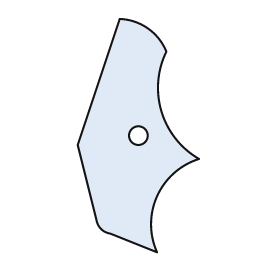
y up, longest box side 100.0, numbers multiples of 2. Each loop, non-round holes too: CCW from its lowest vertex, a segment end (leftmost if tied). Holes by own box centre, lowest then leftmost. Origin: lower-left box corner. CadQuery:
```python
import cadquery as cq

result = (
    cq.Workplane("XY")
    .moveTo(34.0, 0.0)
    .threePointArc((34.0, 24.0), (52.0, 40.0))
    .threePointArc((36.0, 60.0), (38.0, 86.0))
    .threePointArc((30.0, 96.0), (18.0, 100.0))
    .lineTo(0.0, 46.0)
    .lineTo(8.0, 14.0)
    .threePointArc((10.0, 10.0), (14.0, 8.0))
    .close()
    .moveTo(26.0, 50.0)
    .circle(4.0)
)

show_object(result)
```